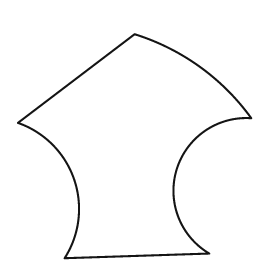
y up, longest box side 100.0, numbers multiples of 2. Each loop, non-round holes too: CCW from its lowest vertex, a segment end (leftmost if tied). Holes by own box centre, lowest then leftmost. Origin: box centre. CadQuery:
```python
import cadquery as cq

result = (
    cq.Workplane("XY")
    .moveTo(-30.0, -48.0)
    .lineTo(32.0, -46.0)
    .threePointArc((18.0, -10.0), (50.0, 12.0))
    .threePointArc((28.0, 34.0), (0.0, 48.0))
    .lineTo(-50.0, 10.0)
    .threePointArc((-26.0, -14.0), (-30.0, -48.0))
    .close()
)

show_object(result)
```